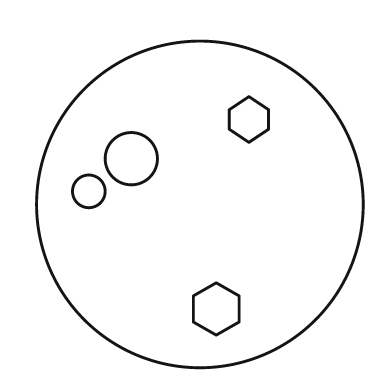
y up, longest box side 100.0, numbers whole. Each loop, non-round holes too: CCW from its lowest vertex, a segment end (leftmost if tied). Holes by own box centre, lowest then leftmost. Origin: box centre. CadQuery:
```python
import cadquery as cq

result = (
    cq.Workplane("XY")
    .moveTo(0.0, 0.0)
    .circle(50.0)
    .moveTo(5.0, -40.0)
    .lineTo(12.0, -36.0)
    .lineTo(12.0, -28.0)
    .lineTo(5.0, -24.0)
    .lineTo(-2.0, -28.0)
    .lineTo(-2.0, -36.0)
    .close()
    .moveTo(-34.0, 4.0)
    .circle(5.0)
    .moveTo(-21.0, 14.0)
    .circle(8.0)
    .moveTo(15.0, 19.0)
    .lineTo(21.0, 23.0)
    .lineTo(21.0, 29.0)
    .lineTo(15.0, 33.0)
    .lineTo(9.0, 29.0)
    .lineTo(9.0, 23.0)
    .close()
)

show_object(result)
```